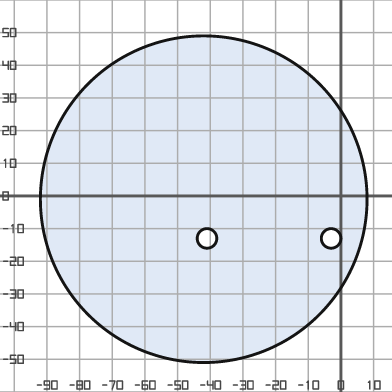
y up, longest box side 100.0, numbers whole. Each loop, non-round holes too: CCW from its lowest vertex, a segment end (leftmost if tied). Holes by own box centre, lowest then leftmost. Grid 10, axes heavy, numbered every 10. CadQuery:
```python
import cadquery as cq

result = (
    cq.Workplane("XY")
    .moveTo(-42.0, -1.0)
    .circle(50.0)
    .moveTo(-41.0, -13.0)
    .circle(3.0)
    .moveTo(-3.0, -13.0)
    .circle(3.0)
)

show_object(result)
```